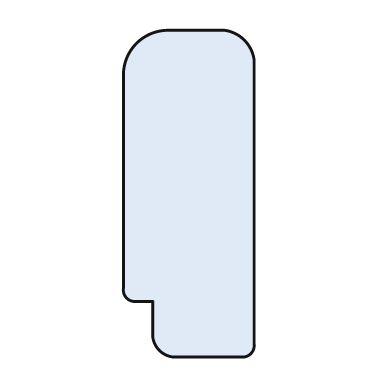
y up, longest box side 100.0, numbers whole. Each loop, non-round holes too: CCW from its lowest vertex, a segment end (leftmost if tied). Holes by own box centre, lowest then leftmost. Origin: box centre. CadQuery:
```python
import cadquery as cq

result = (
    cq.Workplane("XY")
    .moveTo(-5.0, -50.0)
    .lineTo(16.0, -50.0)
    .threePointArc((19.0, -49.0), (20.0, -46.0))
    .lineTo(20.0, 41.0)
    .threePointArc((17.0, 47.0), (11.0, 50.0))
    .lineTo(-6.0, 50.0)
    .threePointArc((-16.0, 46.0), (-20.0, 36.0))
    .lineTo(-20.0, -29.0)
    .threePointArc((-19.0, -32.0), (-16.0, -33.0))
    .lineTo(-11.0, -33.0)
    .lineTo(-11.0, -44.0)
    .threePointArc((-9.0, -48.0), (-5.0, -50.0))
    .close()
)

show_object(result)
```